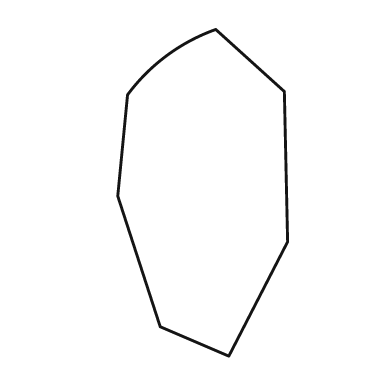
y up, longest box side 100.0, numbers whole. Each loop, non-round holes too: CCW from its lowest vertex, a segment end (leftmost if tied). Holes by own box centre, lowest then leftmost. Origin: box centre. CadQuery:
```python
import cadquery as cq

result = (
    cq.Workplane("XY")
    .moveTo(8.0, -50.0)
    .lineTo(26.0, -15.0)
    .lineTo(25.0, 31.0)
    .lineTo(4.0, 50.0)
    .threePointArc((-11.0, 42.0), (-23.0, 30.0))
    .lineTo(-26.0, -1.0)
    .lineTo(-13.0, -41.0)
    .close()
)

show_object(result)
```